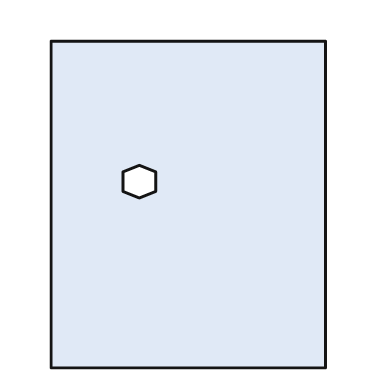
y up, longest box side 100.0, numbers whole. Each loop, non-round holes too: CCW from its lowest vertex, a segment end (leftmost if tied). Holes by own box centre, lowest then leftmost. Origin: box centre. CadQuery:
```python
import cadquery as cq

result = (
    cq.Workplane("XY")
    .moveTo(-42.0, -50.0)
    .lineTo(42.0, -50.0)
    .lineTo(42.0, 50.0)
    .lineTo(-42.0, 50.0)
    .close()
    .moveTo(-15.0, 2.0)
    .lineTo(-10.0, 4.0)
    .lineTo(-10.0, 10.0)
    .lineTo(-15.0, 12.0)
    .lineTo(-20.0, 10.0)
    .lineTo(-20.0, 4.0)
    .close()
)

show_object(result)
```